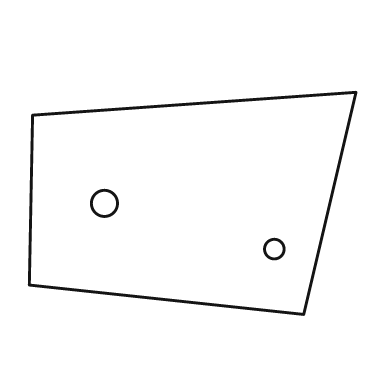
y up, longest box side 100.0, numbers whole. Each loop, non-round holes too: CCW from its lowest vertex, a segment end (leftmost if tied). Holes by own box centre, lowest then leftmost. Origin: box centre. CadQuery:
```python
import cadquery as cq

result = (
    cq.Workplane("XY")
    .moveTo(34.0, -34.0)
    .lineTo(50.0, 34.0)
    .lineTo(-49.0, 27.0)
    .lineTo(-50.0, -25.0)
    .close()
    .moveTo(25.0, -14.0)
    .circle(3.0)
    .moveTo(-27.0, 0.0)
    .circle(4.0)
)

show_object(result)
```